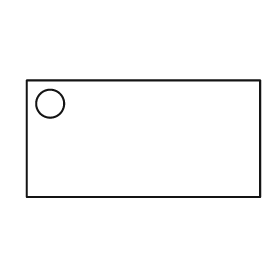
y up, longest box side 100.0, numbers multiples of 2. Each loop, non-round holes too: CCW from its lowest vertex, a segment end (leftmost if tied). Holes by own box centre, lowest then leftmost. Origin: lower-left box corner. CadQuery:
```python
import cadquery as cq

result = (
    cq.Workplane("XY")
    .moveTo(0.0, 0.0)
    .lineTo(100.0, 0.0)
    .lineTo(100.0, 50.0)
    .lineTo(0.0, 50.0)
    .close()
    .moveTo(10.0, 40.0)
    .circle(6.0)
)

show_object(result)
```